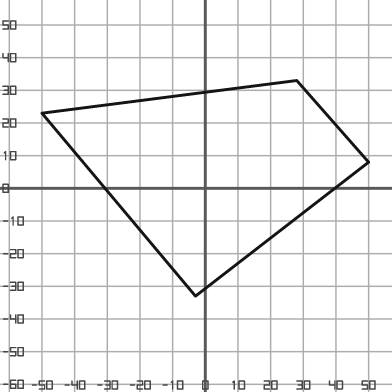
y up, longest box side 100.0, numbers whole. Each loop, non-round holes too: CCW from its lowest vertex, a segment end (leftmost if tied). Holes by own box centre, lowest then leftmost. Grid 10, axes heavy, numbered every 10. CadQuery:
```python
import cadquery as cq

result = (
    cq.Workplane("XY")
    .moveTo(-3.0, -33.0)
    .lineTo(50.0, 8.0)
    .lineTo(28.0, 33.0)
    .lineTo(-50.0, 23.0)
    .close()
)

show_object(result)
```